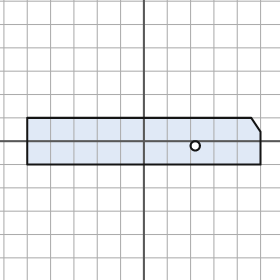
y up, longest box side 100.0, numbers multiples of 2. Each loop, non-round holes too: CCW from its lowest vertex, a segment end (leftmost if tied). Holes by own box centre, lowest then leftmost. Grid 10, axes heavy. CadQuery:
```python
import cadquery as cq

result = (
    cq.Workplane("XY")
    .moveTo(-50.0, -10.0)
    .lineTo(50.0, -10.0)
    .lineTo(50.0, 4.0)
    .lineTo(46.0, 10.0)
    .lineTo(-50.0, 10.0)
    .close()
    .moveTo(22.0, -2.0)
    .circle(2.0)
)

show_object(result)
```